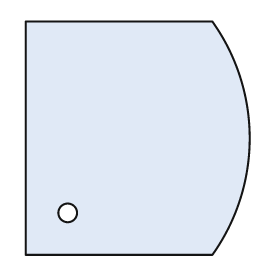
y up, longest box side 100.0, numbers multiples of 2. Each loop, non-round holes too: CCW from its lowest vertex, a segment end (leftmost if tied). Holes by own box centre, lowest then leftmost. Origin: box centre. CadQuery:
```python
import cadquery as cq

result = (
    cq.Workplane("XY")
    .moveTo(-48.0, -50.0)
    .lineTo(32.0, -50.0)
    .threePointArc((48.0, 0.0), (32.0, 50.0))
    .lineTo(-48.0, 50.0)
    .close()
    .moveTo(-30.0, -32.0)
    .circle(4.0)
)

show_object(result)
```